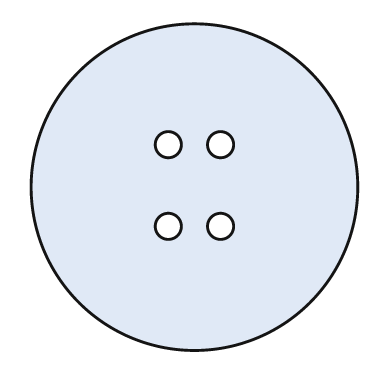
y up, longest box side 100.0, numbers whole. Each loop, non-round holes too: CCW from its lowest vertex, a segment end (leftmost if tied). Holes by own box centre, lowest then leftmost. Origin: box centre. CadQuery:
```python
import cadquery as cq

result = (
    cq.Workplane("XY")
    .moveTo(0.0, 0.0)
    .circle(50.0)
    .moveTo(-8.0, -12.0)
    .circle(4.0)
    .moveTo(8.0, -12.0)
    .circle(4.0)
    .moveTo(-8.0, 13.0)
    .circle(4.0)
    .moveTo(8.0, 13.0)
    .circle(4.0)
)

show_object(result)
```